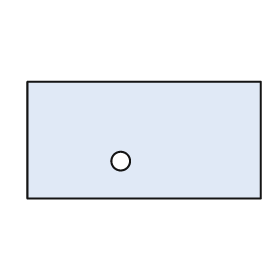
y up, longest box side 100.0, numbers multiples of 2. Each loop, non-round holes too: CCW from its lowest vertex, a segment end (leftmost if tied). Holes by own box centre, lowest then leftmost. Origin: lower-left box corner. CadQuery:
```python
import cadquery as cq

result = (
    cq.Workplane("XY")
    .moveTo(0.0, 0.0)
    .lineTo(100.0, 0.0)
    .lineTo(100.0, 50.0)
    .lineTo(0.0, 50.0)
    .close()
    .moveTo(40.0, 16.0)
    .circle(4.0)
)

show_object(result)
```